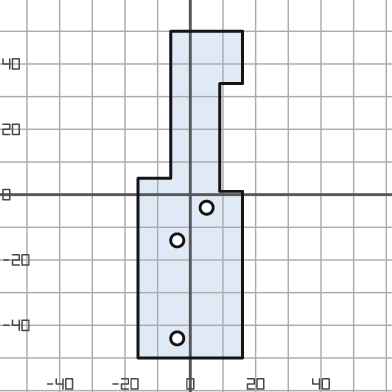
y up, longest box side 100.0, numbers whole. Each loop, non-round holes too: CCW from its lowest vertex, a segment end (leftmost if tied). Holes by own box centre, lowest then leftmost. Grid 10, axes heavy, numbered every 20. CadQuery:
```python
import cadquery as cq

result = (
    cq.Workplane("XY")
    .moveTo(-16.0, -50.0)
    .lineTo(16.0, -50.0)
    .lineTo(16.0, 1.0)
    .lineTo(9.0, 1.0)
    .lineTo(9.0, 34.0)
    .lineTo(16.0, 34.0)
    .lineTo(16.0, 50.0)
    .lineTo(-6.0, 50.0)
    .lineTo(-6.0, 5.0)
    .lineTo(-16.0, 5.0)
    .close()
    .moveTo(-4.0, -44.0)
    .circle(2.0)
    .moveTo(-4.0, -14.0)
    .circle(2.0)
    .moveTo(5.0, -4.0)
    .circle(2.0)
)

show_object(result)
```